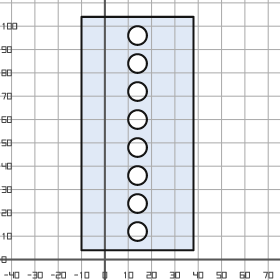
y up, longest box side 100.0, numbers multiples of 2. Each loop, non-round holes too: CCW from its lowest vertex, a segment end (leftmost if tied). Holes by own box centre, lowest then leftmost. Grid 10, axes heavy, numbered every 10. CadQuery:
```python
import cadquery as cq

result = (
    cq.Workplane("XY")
    .moveTo(-10.0, 4.0)
    .lineTo(38.0, 4.0)
    .lineTo(38.0, 104.0)
    .lineTo(-10.0, 104.0)
    .close()
    .moveTo(14.0, 12.0)
    .circle(4.0)
    .moveTo(14.0, 24.0)
    .circle(4.0)
    .moveTo(14.0, 36.0)
    .circle(4.0)
    .moveTo(14.0, 48.0)
    .circle(4.0)
    .moveTo(14.0, 60.0)
    .circle(4.0)
    .moveTo(14.0, 72.0)
    .circle(4.0)
    .moveTo(14.0, 84.0)
    .circle(4.0)
    .moveTo(14.0, 96.0)
    .circle(4.0)
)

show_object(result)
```